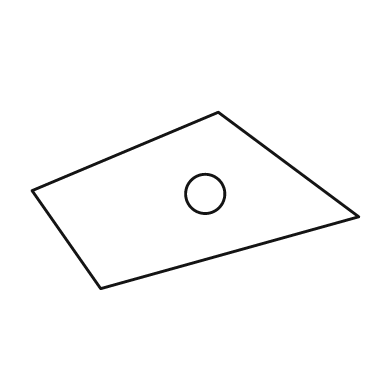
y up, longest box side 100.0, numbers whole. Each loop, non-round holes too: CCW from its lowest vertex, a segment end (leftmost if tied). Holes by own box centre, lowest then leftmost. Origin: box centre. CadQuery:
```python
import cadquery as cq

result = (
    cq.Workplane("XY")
    .moveTo(-29.0, -27.0)
    .lineTo(50.0, -5.0)
    .lineTo(7.0, 27.0)
    .lineTo(-50.0, 3.0)
    .close()
    .moveTo(3.0, 2.0)
    .circle(6.0)
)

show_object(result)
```